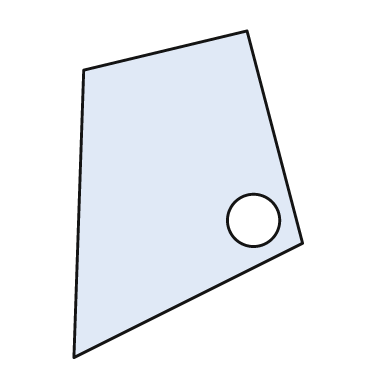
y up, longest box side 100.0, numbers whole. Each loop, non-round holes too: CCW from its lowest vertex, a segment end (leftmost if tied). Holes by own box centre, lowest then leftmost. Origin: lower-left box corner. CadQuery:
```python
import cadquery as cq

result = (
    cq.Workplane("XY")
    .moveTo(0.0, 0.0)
    .lineTo(70.0, 35.0)
    .lineTo(53.0, 100.0)
    .lineTo(3.0, 88.0)
    .close()
    .moveTo(55.0, 42.0)
    .circle(8.0)
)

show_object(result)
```